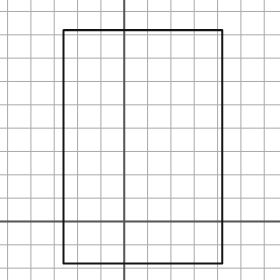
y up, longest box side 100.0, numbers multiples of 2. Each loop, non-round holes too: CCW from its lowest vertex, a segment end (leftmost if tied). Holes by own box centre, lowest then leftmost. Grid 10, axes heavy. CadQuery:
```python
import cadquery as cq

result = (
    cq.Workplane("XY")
    .moveTo(-26.0, -18.0)
    .lineTo(42.0, -18.0)
    .lineTo(42.0, 82.0)
    .lineTo(-26.0, 82.0)
    .close()
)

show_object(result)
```